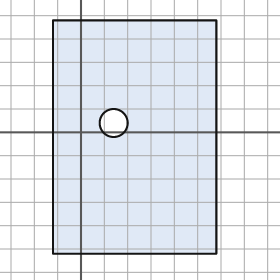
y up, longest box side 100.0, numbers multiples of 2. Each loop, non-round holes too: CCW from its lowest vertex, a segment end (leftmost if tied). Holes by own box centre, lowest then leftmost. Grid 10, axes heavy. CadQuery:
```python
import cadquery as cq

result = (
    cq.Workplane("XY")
    .moveTo(-12.0, -52.0)
    .lineTo(58.0, -52.0)
    .lineTo(58.0, 48.0)
    .lineTo(-12.0, 48.0)
    .close()
    .moveTo(14.0, 4.0)
    .circle(6.0)
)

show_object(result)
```